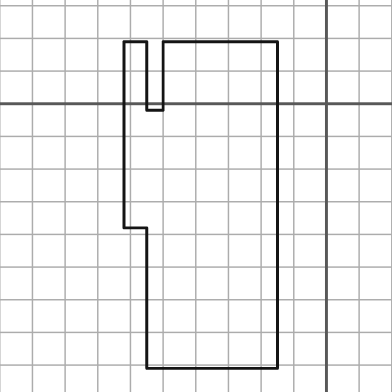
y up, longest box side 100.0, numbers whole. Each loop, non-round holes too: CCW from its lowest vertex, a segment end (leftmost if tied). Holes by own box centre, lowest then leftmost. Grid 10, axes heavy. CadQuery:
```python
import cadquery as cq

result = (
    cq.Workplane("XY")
    .moveTo(-55.0, -81.0)
    .lineTo(-15.0, -81.0)
    .lineTo(-15.0, 19.0)
    .lineTo(-50.0, 19.0)
    .lineTo(-50.0, -2.0)
    .lineTo(-55.0, -2.0)
    .lineTo(-55.0, 19.0)
    .lineTo(-62.0, 19.0)
    .lineTo(-62.0, -38.0)
    .lineTo(-55.0, -38.0)
    .close()
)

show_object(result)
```